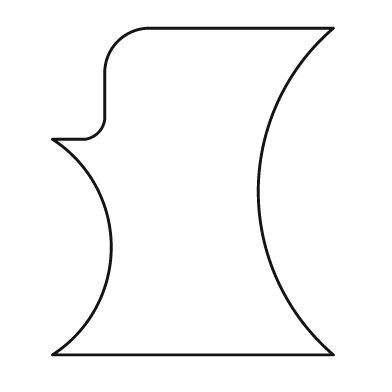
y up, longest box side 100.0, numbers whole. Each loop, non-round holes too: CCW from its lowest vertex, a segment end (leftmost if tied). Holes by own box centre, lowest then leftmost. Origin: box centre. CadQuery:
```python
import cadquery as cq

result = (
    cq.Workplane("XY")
    .moveTo(-43.0, -50.0)
    .lineTo(43.0, -50.0)
    .threePointArc((20.0, 0.0), (43.0, 50.0))
    .lineTo(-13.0, 50.0)
    .threePointArc((-23.0, 46.0), (-27.0, 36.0))
    .lineTo(-27.0, 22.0)
    .threePointArc((-29.0, 18.0), (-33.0, 16.0))
    .lineTo(-43.0, 16.0)
    .threePointArc((-25.0, -17.0), (-43.0, -50.0))
    .close()
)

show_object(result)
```